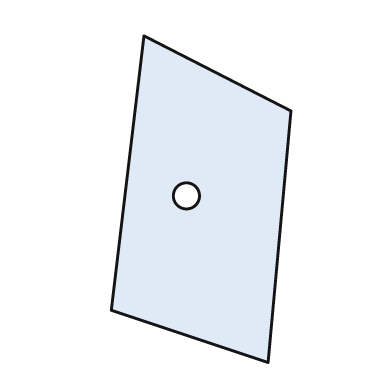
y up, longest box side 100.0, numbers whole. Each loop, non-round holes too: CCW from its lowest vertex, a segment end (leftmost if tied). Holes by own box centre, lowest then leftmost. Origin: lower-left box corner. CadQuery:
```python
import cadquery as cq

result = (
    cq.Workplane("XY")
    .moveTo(48.0, 0.0)
    .lineTo(55.0, 77.0)
    .lineTo(10.0, 100.0)
    .lineTo(0.0, 16.0)
    .close()
    .moveTo(23.0, 51.0)
    .circle(4.0)
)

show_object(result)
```